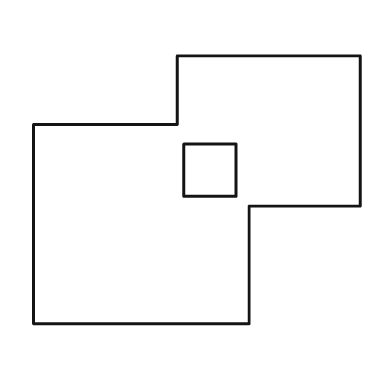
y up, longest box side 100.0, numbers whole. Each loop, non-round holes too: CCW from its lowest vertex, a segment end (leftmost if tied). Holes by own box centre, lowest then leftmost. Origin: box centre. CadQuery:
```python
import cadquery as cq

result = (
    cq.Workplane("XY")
    .moveTo(-50.0, -41.0)
    .lineTo(16.0, -41.0)
    .lineTo(16.0, -5.0)
    .lineTo(50.0, -5.0)
    .lineTo(50.0, 41.0)
    .lineTo(-6.0, 41.0)
    .lineTo(-6.0, 20.0)
    .lineTo(-50.0, 20.0)
    .close()
    .moveTo(-4.0, -2.0)
    .lineTo(12.0, -2.0)
    .lineTo(12.0, 14.0)
    .lineTo(-4.0, 14.0)
    .close()
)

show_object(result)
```